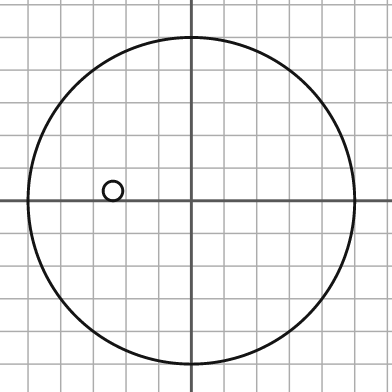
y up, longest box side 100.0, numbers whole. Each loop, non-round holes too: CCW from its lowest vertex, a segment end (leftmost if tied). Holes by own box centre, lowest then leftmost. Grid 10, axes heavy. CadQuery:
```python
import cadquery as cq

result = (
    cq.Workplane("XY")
    .moveTo(0.0, 0.0)
    .circle(50.0)
    .moveTo(-24.0, 3.0)
    .circle(3.0)
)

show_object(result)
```